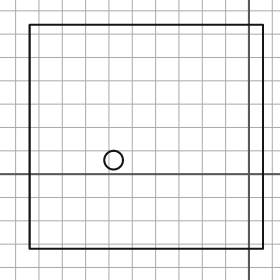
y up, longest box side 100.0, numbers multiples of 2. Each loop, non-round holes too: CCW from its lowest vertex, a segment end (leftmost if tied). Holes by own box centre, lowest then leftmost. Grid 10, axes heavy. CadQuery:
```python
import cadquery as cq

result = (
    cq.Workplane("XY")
    .moveTo(-94.0, -32.0)
    .lineTo(6.0, -32.0)
    .lineTo(6.0, 64.0)
    .lineTo(-94.0, 64.0)
    .close()
    .moveTo(-58.0, 6.0)
    .circle(4.0)
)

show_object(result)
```